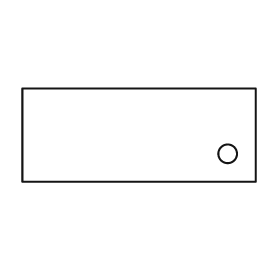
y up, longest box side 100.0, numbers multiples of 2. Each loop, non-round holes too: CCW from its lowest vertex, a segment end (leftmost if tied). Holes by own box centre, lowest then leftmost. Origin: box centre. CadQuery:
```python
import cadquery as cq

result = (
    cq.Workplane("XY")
    .moveTo(-50.0, -20.0)
    .lineTo(50.0, -20.0)
    .lineTo(50.0, 20.0)
    .lineTo(-50.0, 20.0)
    .close()
    .moveTo(38.0, -8.0)
    .circle(4.0)
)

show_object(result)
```